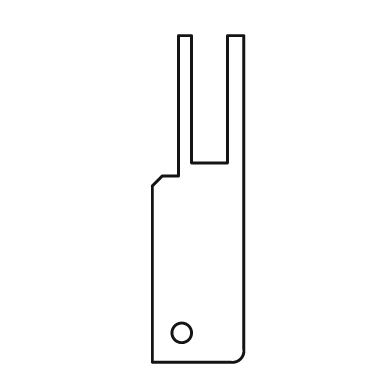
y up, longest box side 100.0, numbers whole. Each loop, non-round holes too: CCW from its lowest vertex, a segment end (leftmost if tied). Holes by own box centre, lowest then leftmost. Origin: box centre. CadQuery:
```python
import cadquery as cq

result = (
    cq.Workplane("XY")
    .moveTo(-14.0, -50.0)
    .lineTo(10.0, -50.0)
    .threePointArc((13.0, -49.0), (14.0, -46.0))
    .lineTo(14.0, 50.0)
    .lineTo(9.0, 50.0)
    .lineTo(9.0, 11.0)
    .lineTo(-2.0, 11.0)
    .lineTo(-2.0, 50.0)
    .lineTo(-6.0, 50.0)
    .lineTo(-6.0, 7.0)
    .lineTo(-11.0, 7.0)
    .lineTo(-14.0, 4.0)
    .close()
    .moveTo(-5.0, -41.0)
    .circle(3.0)
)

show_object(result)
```